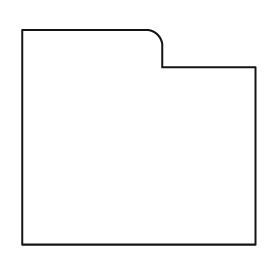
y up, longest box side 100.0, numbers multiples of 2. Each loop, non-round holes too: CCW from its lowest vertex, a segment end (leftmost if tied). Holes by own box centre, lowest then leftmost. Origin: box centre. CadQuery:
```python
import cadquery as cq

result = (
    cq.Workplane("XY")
    .moveTo(-50.0, -46.0)
    .lineTo(50.0, -46.0)
    .lineTo(50.0, 30.0)
    .lineTo(10.0, 30.0)
    .lineTo(10.0, 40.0)
    .threePointArc((8.0, 44.0), (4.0, 46.0))
    .lineTo(-50.0, 46.0)
    .close()
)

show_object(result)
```